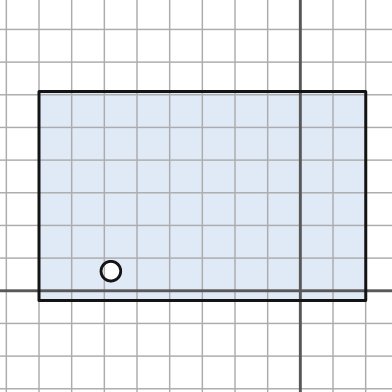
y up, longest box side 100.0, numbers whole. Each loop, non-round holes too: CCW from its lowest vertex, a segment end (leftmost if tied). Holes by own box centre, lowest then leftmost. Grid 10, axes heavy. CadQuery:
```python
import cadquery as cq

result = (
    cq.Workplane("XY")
    .moveTo(-80.0, -3.0)
    .lineTo(20.0, -3.0)
    .lineTo(20.0, 61.0)
    .lineTo(-80.0, 61.0)
    .close()
    .moveTo(-58.0, 6.0)
    .circle(3.0)
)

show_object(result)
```